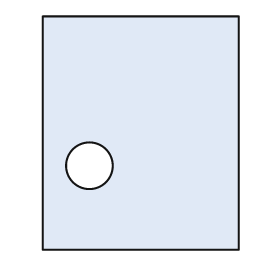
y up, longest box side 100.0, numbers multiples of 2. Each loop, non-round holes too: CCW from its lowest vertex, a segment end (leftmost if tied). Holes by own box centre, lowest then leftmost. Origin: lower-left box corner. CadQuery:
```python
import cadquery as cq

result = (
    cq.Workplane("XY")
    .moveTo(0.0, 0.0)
    .lineTo(84.0, 0.0)
    .lineTo(84.0, 100.0)
    .lineTo(0.0, 100.0)
    .close()
    .moveTo(20.0, 36.0)
    .circle(10.0)
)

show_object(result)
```